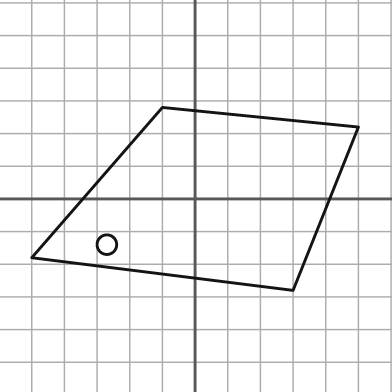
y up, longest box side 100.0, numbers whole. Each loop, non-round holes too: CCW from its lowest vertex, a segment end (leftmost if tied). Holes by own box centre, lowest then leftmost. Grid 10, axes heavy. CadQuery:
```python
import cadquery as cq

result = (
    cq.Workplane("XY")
    .moveTo(30.0, -28.0)
    .lineTo(50.0, 22.0)
    .lineTo(-10.0, 28.0)
    .lineTo(-50.0, -18.0)
    .close()
    .moveTo(-27.0, -14.0)
    .circle(3.0)
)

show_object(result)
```